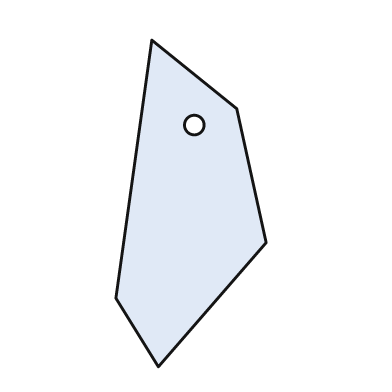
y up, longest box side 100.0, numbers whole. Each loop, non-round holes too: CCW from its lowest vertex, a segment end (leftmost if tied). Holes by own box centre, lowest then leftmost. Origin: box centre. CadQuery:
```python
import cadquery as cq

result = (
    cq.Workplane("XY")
    .moveTo(-10.0, -50.0)
    .lineTo(23.0, -12.0)
    .lineTo(14.0, 29.0)
    .lineTo(-12.0, 50.0)
    .lineTo(-23.0, -29.0)
    .close()
    .moveTo(1.0, 24.0)
    .circle(3.0)
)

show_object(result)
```